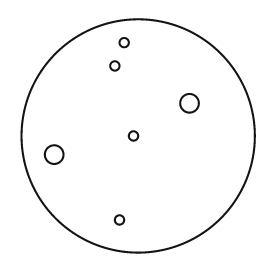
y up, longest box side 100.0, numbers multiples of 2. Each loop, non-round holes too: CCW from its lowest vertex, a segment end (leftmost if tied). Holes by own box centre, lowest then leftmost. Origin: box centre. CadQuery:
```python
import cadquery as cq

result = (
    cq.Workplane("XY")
    .moveTo(0.0, 0.0)
    .circle(50.0)
    .moveTo(-8.0, -36.0)
    .circle(2.0)
    .moveTo(-36.0, -8.0)
    .circle(4.0)
    .moveTo(-2.0, 0.0)
    .circle(2.0)
    .moveTo(22.0, 14.0)
    .circle(4.0)
    .moveTo(-10.0, 30.0)
    .circle(2.0)
    .moveTo(-6.0, 40.0)
    .circle(2.0)
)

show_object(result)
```